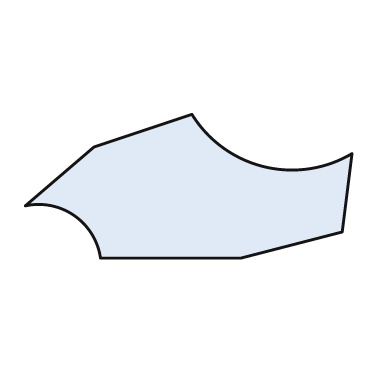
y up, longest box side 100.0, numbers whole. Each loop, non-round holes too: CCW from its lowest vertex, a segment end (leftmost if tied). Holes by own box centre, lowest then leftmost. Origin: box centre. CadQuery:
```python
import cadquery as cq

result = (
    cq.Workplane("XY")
    .moveTo(-27.0, -22.0)
    .lineTo(16.0, -22.0)
    .lineTo(47.0, -14.0)
    .lineTo(50.0, 10.0)
    .threePointArc((23.0, 6.0), (1.0, 22.0))
    .lineTo(-29.0, 12.0)
    .lineTo(-50.0, -6.0)
    .threePointArc((-35.0, -9.0), (-27.0, -22.0))
    .close()
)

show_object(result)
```